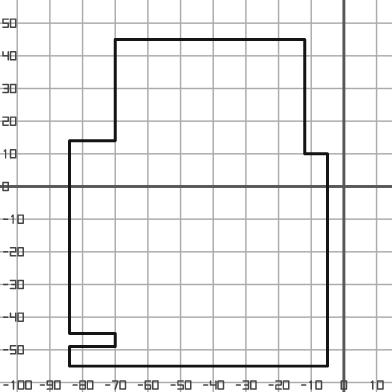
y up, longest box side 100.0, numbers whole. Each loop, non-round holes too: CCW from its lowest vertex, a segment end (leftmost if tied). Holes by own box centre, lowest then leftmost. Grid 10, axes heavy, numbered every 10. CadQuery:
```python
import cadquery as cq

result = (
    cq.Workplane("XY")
    .moveTo(-84.0, -55.0)
    .lineTo(-5.0, -55.0)
    .lineTo(-5.0, 10.0)
    .lineTo(-12.0, 10.0)
    .lineTo(-12.0, 45.0)
    .lineTo(-70.0, 45.0)
    .lineTo(-70.0, 14.0)
    .lineTo(-84.0, 14.0)
    .lineTo(-84.0, -45.0)
    .lineTo(-70.0, -45.0)
    .lineTo(-70.0, -49.0)
    .lineTo(-84.0, -49.0)
    .close()
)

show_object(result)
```